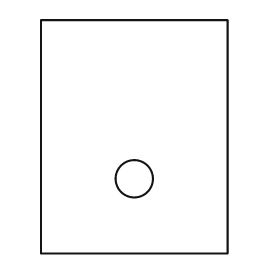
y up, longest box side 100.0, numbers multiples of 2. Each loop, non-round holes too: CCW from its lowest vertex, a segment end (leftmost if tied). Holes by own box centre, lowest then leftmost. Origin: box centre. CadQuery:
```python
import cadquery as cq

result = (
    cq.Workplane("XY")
    .moveTo(-40.0, -50.0)
    .lineTo(40.0, -50.0)
    .lineTo(40.0, 50.0)
    .lineTo(-40.0, 50.0)
    .close()
    .moveTo(0.0, -18.0)
    .circle(8.0)
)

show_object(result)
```